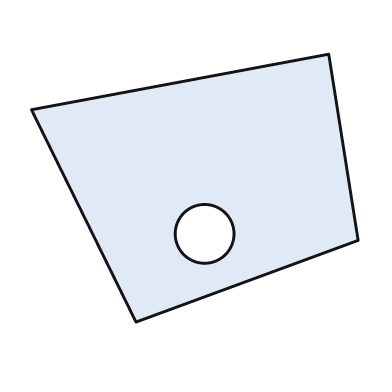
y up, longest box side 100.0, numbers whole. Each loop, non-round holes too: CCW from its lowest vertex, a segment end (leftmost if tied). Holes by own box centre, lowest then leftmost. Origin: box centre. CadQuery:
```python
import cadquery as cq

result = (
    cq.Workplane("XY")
    .moveTo(-18.0, -41.0)
    .lineTo(50.0, -16.0)
    .lineTo(41.0, 41.0)
    .lineTo(-50.0, 24.0)
    .close()
    .moveTo(3.0, -14.0)
    .circle(9.0)
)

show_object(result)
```